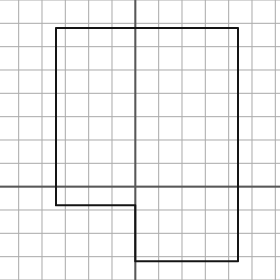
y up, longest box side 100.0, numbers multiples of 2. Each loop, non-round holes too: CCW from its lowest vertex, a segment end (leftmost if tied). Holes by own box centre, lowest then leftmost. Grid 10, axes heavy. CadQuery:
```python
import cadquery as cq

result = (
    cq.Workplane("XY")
    .moveTo(0.0, -32.0)
    .lineTo(44.0, -32.0)
    .lineTo(44.0, 68.0)
    .lineTo(-34.0, 68.0)
    .lineTo(-34.0, -8.0)
    .lineTo(0.0, -8.0)
    .close()
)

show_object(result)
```